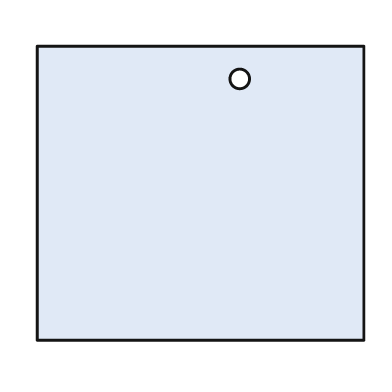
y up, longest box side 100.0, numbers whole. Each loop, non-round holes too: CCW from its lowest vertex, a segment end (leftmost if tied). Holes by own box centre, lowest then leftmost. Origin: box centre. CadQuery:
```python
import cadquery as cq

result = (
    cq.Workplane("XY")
    .moveTo(-50.0, -45.0)
    .lineTo(50.0, -45.0)
    .lineTo(50.0, 45.0)
    .lineTo(-50.0, 45.0)
    .close()
    .moveTo(12.0, 35.0)
    .circle(3.0)
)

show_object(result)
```